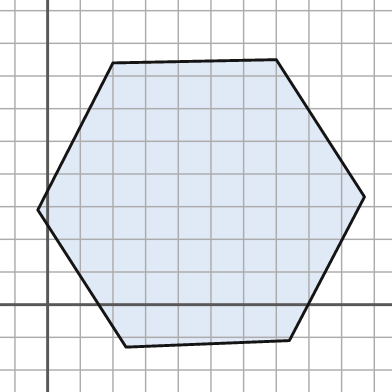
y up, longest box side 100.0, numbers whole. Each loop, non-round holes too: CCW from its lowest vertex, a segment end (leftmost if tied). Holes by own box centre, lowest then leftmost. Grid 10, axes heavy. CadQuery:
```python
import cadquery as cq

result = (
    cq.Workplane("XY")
    .moveTo(24.0, -13.0)
    .lineTo(74.0, -11.0)
    .lineTo(97.0, 33.0)
    .lineTo(70.0, 75.0)
    .lineTo(20.0, 74.0)
    .lineTo(-3.0, 29.0)
    .close()
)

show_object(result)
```